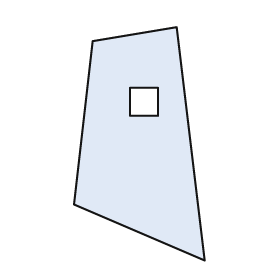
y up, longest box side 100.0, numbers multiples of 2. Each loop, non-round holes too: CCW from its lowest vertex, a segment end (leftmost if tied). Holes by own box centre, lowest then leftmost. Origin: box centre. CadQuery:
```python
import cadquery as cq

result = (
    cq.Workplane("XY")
    .moveTo(28.0, -50.0)
    .lineTo(16.0, 50.0)
    .lineTo(-20.0, 44.0)
    .lineTo(-28.0, -26.0)
    .close()
    .moveTo(-4.0, 12.0)
    .lineTo(8.0, 12.0)
    .lineTo(8.0, 24.0)
    .lineTo(-4.0, 24.0)
    .close()
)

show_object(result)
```